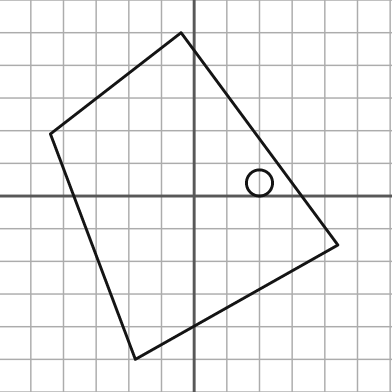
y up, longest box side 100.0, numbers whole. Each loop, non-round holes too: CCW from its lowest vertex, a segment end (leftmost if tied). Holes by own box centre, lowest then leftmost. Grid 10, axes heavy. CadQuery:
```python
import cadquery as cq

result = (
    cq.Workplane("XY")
    .moveTo(-18.0, -50.0)
    .lineTo(44.0, -15.0)
    .lineTo(-4.0, 50.0)
    .lineTo(-44.0, 19.0)
    .close()
    .moveTo(20.0, 4.0)
    .circle(4.0)
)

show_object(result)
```